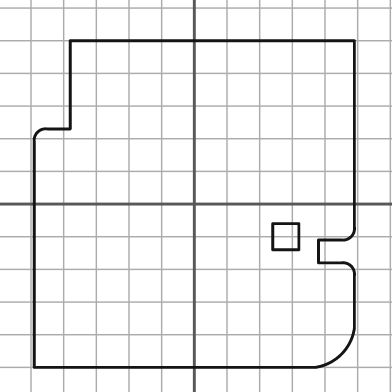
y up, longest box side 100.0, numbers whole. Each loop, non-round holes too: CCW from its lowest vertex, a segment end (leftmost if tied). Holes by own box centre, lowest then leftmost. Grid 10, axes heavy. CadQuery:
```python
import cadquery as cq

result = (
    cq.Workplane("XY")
    .moveTo(-49.0, -50.0)
    .lineTo(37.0, -50.0)
    .threePointArc((45.0, -46.0), (49.0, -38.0))
    .lineTo(49.0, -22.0)
    .threePointArc((48.0, -19.0), (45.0, -18.0))
    .lineTo(38.0, -18.0)
    .lineTo(38.0, -11.0)
    .lineTo(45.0, -11.0)
    .threePointArc((48.0, -10.0), (49.0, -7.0))
    .lineTo(49.0, 50.0)
    .lineTo(-38.0, 50.0)
    .lineTo(-38.0, 23.0)
    .lineTo(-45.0, 23.0)
    .threePointArc((-48.0, 22.0), (-49.0, 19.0))
    .close()
    .moveTo(24.0, -14.0)
    .lineTo(32.0, -14.0)
    .lineTo(32.0, -6.0)
    .lineTo(24.0, -6.0)
    .close()
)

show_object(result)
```